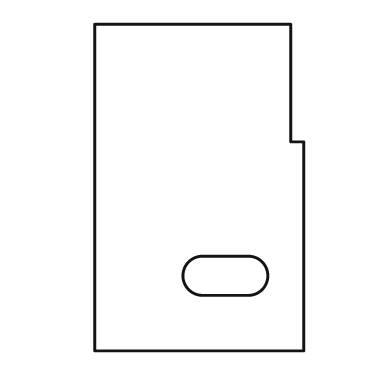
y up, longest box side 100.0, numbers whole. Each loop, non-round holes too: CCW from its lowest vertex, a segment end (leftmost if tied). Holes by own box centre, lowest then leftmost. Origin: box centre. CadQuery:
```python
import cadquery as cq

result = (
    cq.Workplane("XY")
    .moveTo(-32.0, -50.0)
    .lineTo(32.0, -50.0)
    .lineTo(32.0, 14.0)
    .lineTo(28.0, 14.0)
    .lineTo(28.0, 50.0)
    .lineTo(-32.0, 50.0)
    .close()
    .moveTo(1.0, -33.0)
    .lineTo(15.0, -33.0)
    .threePointArc((21.0, -27.0), (15.0, -21.0))
    .lineTo(1.0, -21.0)
    .threePointArc((-5.0, -27.0), (1.0, -33.0))
    .close()
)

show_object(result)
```